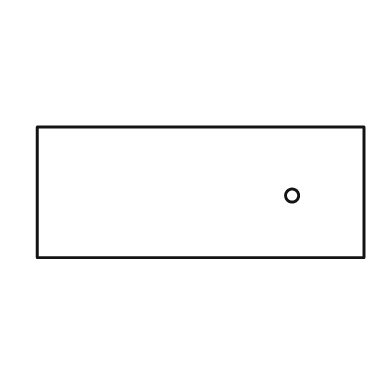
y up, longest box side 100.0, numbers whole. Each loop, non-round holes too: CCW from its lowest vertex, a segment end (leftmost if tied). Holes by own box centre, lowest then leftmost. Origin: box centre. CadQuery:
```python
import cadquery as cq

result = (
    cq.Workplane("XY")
    .moveTo(-50.0, -20.0)
    .lineTo(50.0, -20.0)
    .lineTo(50.0, 20.0)
    .lineTo(-50.0, 20.0)
    .close()
    .moveTo(28.0, -1.0)
    .circle(2.0)
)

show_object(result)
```